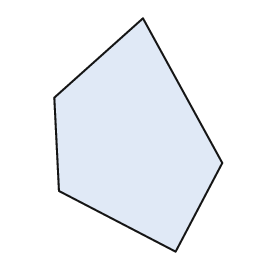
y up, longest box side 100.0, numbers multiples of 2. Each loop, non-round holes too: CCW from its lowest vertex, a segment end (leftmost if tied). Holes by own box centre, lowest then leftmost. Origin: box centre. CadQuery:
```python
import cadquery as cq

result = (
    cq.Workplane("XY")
    .moveTo(16.0, -50.0)
    .lineTo(36.0, -12.0)
    .lineTo(2.0, 50.0)
    .lineTo(-36.0, 16.0)
    .lineTo(-34.0, -24.0)
    .close()
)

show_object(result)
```